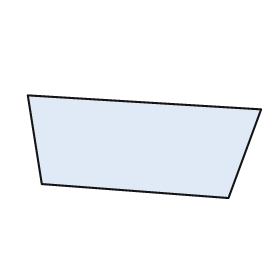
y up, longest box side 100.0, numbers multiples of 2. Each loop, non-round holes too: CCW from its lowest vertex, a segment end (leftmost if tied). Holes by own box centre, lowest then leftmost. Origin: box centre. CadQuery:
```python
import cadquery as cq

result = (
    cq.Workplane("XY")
    .moveTo(36.0, -22.0)
    .lineTo(50.0, 16.0)
    .lineTo(-50.0, 22.0)
    .lineTo(-44.0, -16.0)
    .close()
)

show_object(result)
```